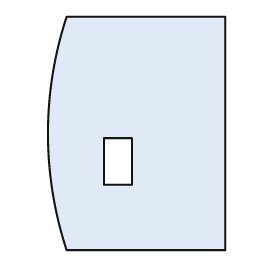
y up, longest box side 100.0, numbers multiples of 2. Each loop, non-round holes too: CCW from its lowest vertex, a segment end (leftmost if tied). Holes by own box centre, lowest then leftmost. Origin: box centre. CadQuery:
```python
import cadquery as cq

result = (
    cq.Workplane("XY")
    .moveTo(-30.0, -50.0)
    .lineTo(38.0, -50.0)
    .lineTo(38.0, 50.0)
    .lineTo(-30.0, 50.0)
    .threePointArc((-38.0, 0.0), (-30.0, -50.0))
    .close()
    .moveTo(-14.0, -22.0)
    .lineTo(-2.0, -22.0)
    .lineTo(-2.0, -2.0)
    .lineTo(-14.0, -2.0)
    .close()
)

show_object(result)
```